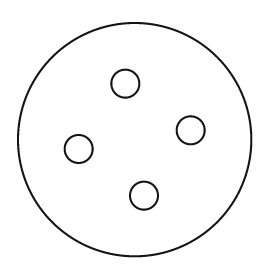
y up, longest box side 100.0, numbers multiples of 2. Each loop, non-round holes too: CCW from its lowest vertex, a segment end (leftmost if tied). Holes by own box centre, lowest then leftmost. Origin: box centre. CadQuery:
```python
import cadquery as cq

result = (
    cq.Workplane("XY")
    .moveTo(0.0, 0.0)
    .circle(50.0)
    .moveTo(4.0, -24.0)
    .circle(6.0)
    .moveTo(-24.0, -4.0)
    .circle(6.0)
    .moveTo(24.0, 4.0)
    .circle(6.0)
    .moveTo(-4.0, 24.0)
    .circle(6.0)
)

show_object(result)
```